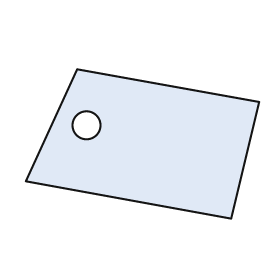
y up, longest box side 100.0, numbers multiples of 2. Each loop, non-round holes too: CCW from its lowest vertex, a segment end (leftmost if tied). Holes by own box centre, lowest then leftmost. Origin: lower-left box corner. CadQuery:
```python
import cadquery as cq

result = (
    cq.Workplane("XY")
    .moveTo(88.0, 0.0)
    .lineTo(100.0, 50.0)
    .lineTo(22.0, 64.0)
    .lineTo(0.0, 16.0)
    .close()
    .moveTo(26.0, 40.0)
    .circle(6.0)
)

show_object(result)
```